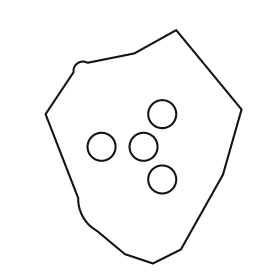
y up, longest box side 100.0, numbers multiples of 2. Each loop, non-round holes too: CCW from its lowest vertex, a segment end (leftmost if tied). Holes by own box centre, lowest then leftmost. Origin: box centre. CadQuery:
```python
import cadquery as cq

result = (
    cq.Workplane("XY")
    .moveTo(4.0, -50.0)
    .lineTo(16.0, -44.0)
    .lineTo(34.0, -12.0)
    .lineTo(42.0, 16.0)
    .lineTo(14.0, 50.0)
    .lineTo(-4.0, 40.0)
    .lineTo(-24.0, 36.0)
    .threePointArc((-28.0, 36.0), (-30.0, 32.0))
    .lineTo(-42.0, 14.0)
    .lineTo(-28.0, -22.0)
    .threePointArc((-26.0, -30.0), (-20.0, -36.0))
    .lineTo(-8.0, -46.0)
    .close()
    .moveTo(8.0, -14.0)
    .circle(6.0)
    .moveTo(-18.0, 0.0)
    .circle(6.0)
    .moveTo(0.0, 0.0)
    .circle(6.0)
    .moveTo(8.0, 14.0)
    .circle(6.0)
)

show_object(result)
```